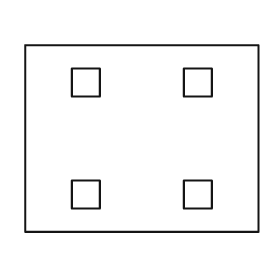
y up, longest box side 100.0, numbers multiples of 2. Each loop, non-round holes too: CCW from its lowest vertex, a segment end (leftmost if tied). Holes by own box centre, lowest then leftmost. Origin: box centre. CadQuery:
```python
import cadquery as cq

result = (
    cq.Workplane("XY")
    .moveTo(-50.0, -40.0)
    .lineTo(50.0, -40.0)
    .lineTo(50.0, 40.0)
    .lineTo(-50.0, 40.0)
    .close()
    .moveTo(-30.0, -30.0)
    .lineTo(-18.0, -30.0)
    .lineTo(-18.0, -18.0)
    .lineTo(-30.0, -18.0)
    .close()
    .moveTo(18.0, -30.0)
    .lineTo(30.0, -30.0)
    .lineTo(30.0, -18.0)
    .lineTo(18.0, -18.0)
    .close()
    .moveTo(-30.0, 18.0)
    .lineTo(-18.0, 18.0)
    .lineTo(-18.0, 30.0)
    .lineTo(-30.0, 30.0)
    .close()
    .moveTo(18.0, 18.0)
    .lineTo(30.0, 18.0)
    .lineTo(30.0, 30.0)
    .lineTo(18.0, 30.0)
    .close()
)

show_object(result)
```